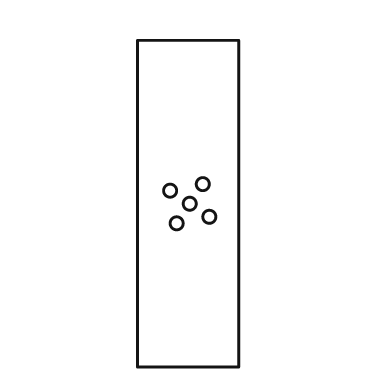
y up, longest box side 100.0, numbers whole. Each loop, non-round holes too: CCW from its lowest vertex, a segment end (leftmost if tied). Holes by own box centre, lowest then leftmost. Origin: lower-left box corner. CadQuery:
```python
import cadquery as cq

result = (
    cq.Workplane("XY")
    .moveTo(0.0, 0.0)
    .lineTo(31.0, 0.0)
    .lineTo(31.0, 100.0)
    .lineTo(0.0, 100.0)
    .close()
    .moveTo(12.0, 44.0)
    .circle(2.0)
    .moveTo(22.0, 46.0)
    .circle(2.0)
    .moveTo(16.0, 50.0)
    .circle(2.0)
    .moveTo(10.0, 54.0)
    .circle(2.0)
    .moveTo(20.0, 56.0)
    .circle(2.0)
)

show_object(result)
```